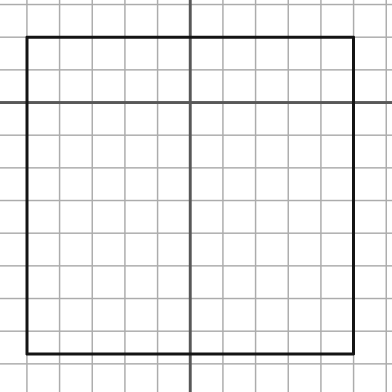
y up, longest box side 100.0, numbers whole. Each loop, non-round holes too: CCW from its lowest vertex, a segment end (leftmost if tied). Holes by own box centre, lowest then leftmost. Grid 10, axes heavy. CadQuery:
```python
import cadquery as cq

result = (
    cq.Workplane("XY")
    .moveTo(-50.0, -77.0)
    .lineTo(50.0, -77.0)
    .lineTo(50.0, 20.0)
    .lineTo(-50.0, 20.0)
    .close()
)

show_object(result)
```